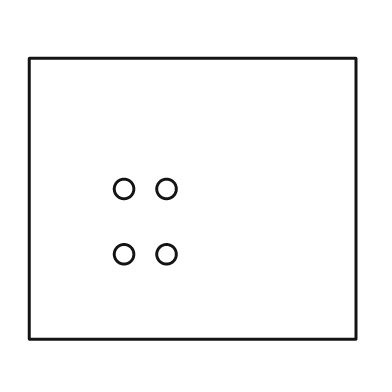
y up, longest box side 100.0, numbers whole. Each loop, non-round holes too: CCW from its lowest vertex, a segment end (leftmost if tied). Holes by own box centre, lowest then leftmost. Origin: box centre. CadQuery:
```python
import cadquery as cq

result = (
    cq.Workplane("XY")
    .moveTo(-50.0, -43.0)
    .lineTo(50.0, -43.0)
    .lineTo(50.0, 43.0)
    .lineTo(-50.0, 43.0)
    .close()
    .moveTo(-21.0, -17.0)
    .circle(3.0)
    .moveTo(-8.0, -17.0)
    .circle(3.0)
    .moveTo(-21.0, 3.0)
    .circle(3.0)
    .moveTo(-8.0, 3.0)
    .circle(3.0)
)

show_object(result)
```